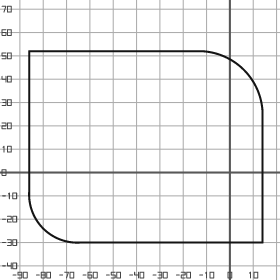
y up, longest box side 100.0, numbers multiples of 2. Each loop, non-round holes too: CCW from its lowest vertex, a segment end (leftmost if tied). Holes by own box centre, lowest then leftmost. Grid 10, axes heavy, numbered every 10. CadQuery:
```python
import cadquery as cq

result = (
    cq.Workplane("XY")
    .moveTo(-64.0, -30.0)
    .lineTo(14.0, -30.0)
    .lineTo(14.0, 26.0)
    .threePointArc((6.0, 44.0), (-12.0, 52.0))
    .lineTo(-86.0, 52.0)
    .lineTo(-86.0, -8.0)
    .threePointArc((-80.0, -24.0), (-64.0, -30.0))
    .close()
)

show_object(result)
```